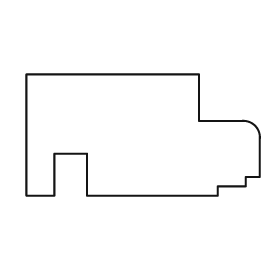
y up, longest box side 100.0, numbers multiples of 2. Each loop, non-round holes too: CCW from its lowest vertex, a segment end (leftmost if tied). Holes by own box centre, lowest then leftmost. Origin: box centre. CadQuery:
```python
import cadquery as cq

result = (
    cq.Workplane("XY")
    .moveTo(-50.0, -26.0)
    .lineTo(-38.0, -26.0)
    .lineTo(-38.0, -8.0)
    .lineTo(-24.0, -8.0)
    .lineTo(-24.0, -26.0)
    .lineTo(32.0, -26.0)
    .lineTo(32.0, -22.0)
    .lineTo(44.0, -22.0)
    .lineTo(44.0, -18.0)
    .lineTo(50.0, -18.0)
    .lineTo(50.0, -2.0)
    .threePointArc((48.0, 4.0), (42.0, 6.0))
    .lineTo(24.0, 6.0)
    .lineTo(24.0, 26.0)
    .lineTo(-50.0, 26.0)
    .close()
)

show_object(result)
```